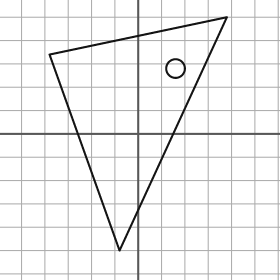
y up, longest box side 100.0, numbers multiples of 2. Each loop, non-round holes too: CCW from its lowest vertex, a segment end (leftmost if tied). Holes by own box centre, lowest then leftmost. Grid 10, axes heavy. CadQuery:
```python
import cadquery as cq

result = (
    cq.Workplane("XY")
    .moveTo(-8.0, -50.0)
    .lineTo(38.0, 50.0)
    .lineTo(-38.0, 34.0)
    .close()
    .moveTo(16.0, 28.0)
    .circle(4.0)
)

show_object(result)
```